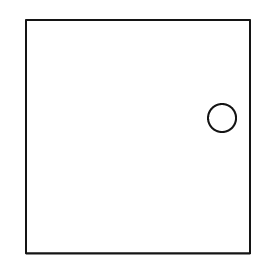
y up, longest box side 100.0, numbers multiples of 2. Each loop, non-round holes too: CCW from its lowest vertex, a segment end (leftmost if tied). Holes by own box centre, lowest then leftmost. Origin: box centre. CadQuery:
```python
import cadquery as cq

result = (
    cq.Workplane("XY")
    .moveTo(-48.0, -50.0)
    .lineTo(48.0, -50.0)
    .lineTo(48.0, 50.0)
    .lineTo(-48.0, 50.0)
    .close()
    .moveTo(36.0, 8.0)
    .circle(6.0)
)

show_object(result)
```